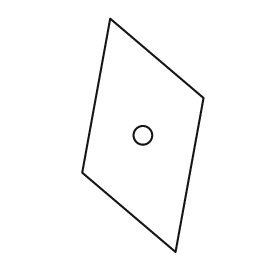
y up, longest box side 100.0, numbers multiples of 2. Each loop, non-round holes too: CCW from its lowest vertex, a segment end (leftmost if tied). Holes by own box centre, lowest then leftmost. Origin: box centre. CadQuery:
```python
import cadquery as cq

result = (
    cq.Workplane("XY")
    .moveTo(14.0, -50.0)
    .lineTo(26.0, 16.0)
    .lineTo(-14.0, 50.0)
    .lineTo(-26.0, -16.0)
    .close()
    .moveTo(0.0, 0.0)
    .circle(4.0)
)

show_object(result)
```